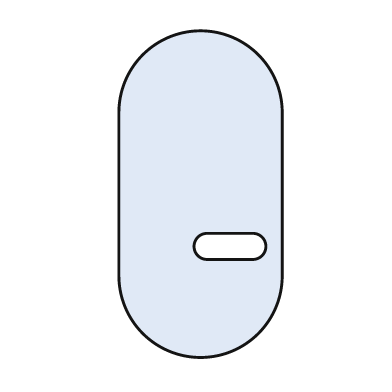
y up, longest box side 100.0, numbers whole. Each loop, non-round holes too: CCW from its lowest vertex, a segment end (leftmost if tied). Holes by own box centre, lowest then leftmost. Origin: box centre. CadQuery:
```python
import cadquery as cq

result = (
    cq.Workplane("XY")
    .moveTo(-25.0, -25.0)
    .threePointArc((0.0, -50.0), (25.0, -25.0))
    .lineTo(25.0, 25.0)
    .threePointArc((0.0, 50.0), (-25.0, 25.0))
    .close()
    .moveTo(2.0, -20.0)
    .lineTo(16.0, -20.0)
    .threePointArc((20.0, -16.0), (16.0, -12.0))
    .lineTo(2.0, -12.0)
    .threePointArc((-2.0, -16.0), (2.0, -20.0))
    .close()
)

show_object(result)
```